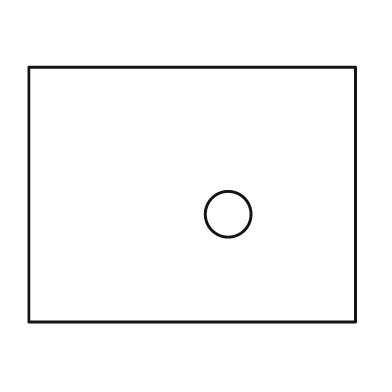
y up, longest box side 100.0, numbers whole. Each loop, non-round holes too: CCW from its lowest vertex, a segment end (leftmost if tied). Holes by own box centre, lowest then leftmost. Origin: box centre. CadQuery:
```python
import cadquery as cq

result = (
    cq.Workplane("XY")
    .moveTo(-50.0, -39.0)
    .lineTo(50.0, -39.0)
    .lineTo(50.0, 39.0)
    .lineTo(-50.0, 39.0)
    .close()
    .moveTo(11.0, -6.0)
    .circle(7.0)
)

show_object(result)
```